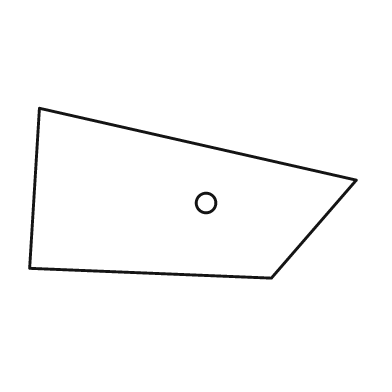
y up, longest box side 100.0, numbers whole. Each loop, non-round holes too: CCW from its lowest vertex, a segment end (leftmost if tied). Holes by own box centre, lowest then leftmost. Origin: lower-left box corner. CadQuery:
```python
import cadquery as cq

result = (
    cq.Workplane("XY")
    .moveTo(74.0, 0.0)
    .lineTo(100.0, 30.0)
    .lineTo(3.0, 52.0)
    .lineTo(0.0, 3.0)
    .close()
    .moveTo(54.0, 23.0)
    .circle(3.0)
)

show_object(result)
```